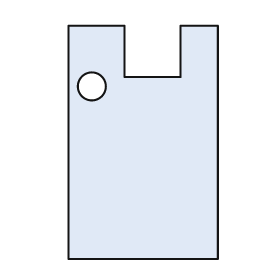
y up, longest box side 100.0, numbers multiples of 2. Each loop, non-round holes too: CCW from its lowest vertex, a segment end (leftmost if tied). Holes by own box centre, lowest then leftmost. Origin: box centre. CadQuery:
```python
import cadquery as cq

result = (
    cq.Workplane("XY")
    .moveTo(-32.0, -50.0)
    .lineTo(32.0, -50.0)
    .lineTo(32.0, 50.0)
    .lineTo(16.0, 50.0)
    .lineTo(16.0, 28.0)
    .lineTo(-8.0, 28.0)
    .lineTo(-8.0, 50.0)
    .lineTo(-32.0, 50.0)
    .close()
    .moveTo(-22.0, 24.0)
    .circle(6.0)
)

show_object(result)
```